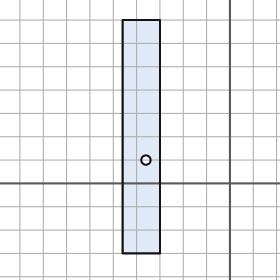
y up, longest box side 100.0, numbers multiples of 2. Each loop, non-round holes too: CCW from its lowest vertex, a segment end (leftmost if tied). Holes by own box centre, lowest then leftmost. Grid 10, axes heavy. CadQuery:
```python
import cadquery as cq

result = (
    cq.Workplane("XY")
    .moveTo(-46.0, -30.0)
    .lineTo(-30.0, -30.0)
    .lineTo(-30.0, 70.0)
    .lineTo(-46.0, 70.0)
    .close()
    .moveTo(-36.0, 10.0)
    .circle(2.0)
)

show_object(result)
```